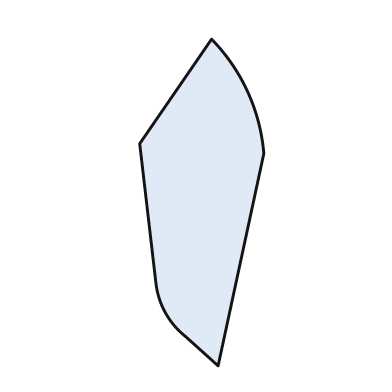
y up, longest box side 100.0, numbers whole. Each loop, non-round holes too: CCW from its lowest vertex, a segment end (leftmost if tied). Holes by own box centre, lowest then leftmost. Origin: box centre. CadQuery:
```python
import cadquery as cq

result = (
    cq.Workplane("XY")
    .moveTo(5.0, -50.0)
    .lineTo(19.0, 15.0)
    .threePointArc((14.0, 34.0), (3.0, 50.0))
    .lineTo(-19.0, 18.0)
    .lineTo(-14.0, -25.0)
    .threePointArc((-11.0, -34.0), (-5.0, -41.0))
    .close()
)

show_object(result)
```